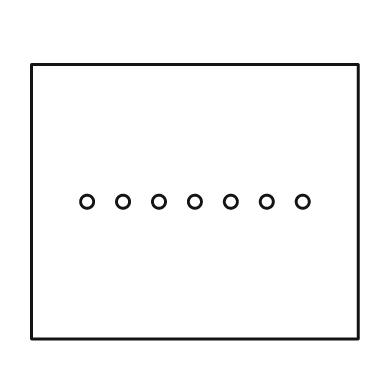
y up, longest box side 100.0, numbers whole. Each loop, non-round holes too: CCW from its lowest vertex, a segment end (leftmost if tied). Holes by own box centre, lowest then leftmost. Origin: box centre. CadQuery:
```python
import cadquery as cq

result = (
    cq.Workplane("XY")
    .moveTo(-50.0, -42.0)
    .lineTo(50.0, -42.0)
    .lineTo(50.0, 42.0)
    .lineTo(-50.0, 42.0)
    .close()
    .moveTo(-33.0, 0.0)
    .circle(2.0)
    .moveTo(-22.0, 0.0)
    .circle(2.0)
    .moveTo(-11.0, 0.0)
    .circle(2.0)
    .moveTo(0.0, 0.0)
    .circle(2.0)
    .moveTo(11.0, 0.0)
    .circle(2.0)
    .moveTo(22.0, 0.0)
    .circle(2.0)
    .moveTo(33.0, 0.0)
    .circle(2.0)
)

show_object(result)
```